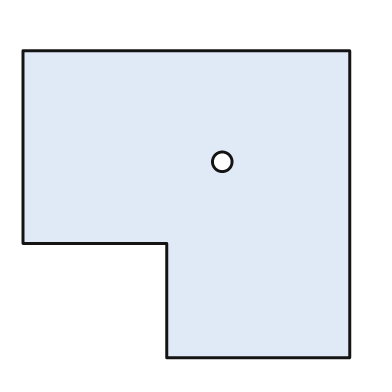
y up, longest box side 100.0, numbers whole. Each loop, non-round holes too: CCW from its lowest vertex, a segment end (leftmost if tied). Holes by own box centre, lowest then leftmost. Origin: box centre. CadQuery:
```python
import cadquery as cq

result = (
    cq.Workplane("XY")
    .moveTo(-6.0, -47.0)
    .lineTo(50.0, -47.0)
    .lineTo(50.0, 47.0)
    .lineTo(-50.0, 47.0)
    .lineTo(-50.0, -12.0)
    .lineTo(-6.0, -12.0)
    .close()
    .moveTo(11.0, 13.0)
    .circle(3.0)
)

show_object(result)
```